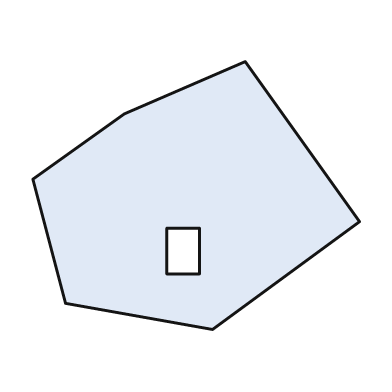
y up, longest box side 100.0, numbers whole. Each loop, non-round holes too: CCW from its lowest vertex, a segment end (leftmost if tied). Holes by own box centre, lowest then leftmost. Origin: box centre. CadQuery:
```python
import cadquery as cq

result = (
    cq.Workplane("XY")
    .moveTo(5.0, -41.0)
    .lineTo(50.0, -8.0)
    .lineTo(15.0, 41.0)
    .lineTo(-22.0, 25.0)
    .lineTo(-50.0, 5.0)
    .lineTo(-40.0, -33.0)
    .close()
    .moveTo(-9.0, -24.0)
    .lineTo(1.0, -24.0)
    .lineTo(1.0, -10.0)
    .lineTo(-9.0, -10.0)
    .close()
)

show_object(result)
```